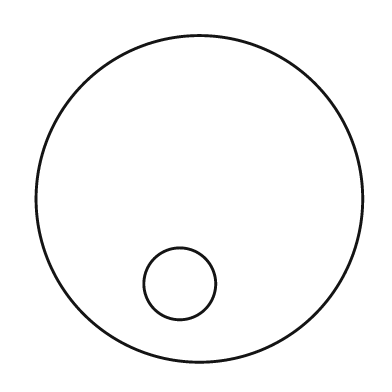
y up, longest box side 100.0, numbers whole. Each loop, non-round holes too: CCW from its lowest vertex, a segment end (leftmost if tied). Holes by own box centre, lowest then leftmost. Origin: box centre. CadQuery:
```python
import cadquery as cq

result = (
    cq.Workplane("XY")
    .moveTo(0.0, 0.0)
    .circle(50.0)
    .moveTo(-6.0, -26.0)
    .circle(11.0)
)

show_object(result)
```